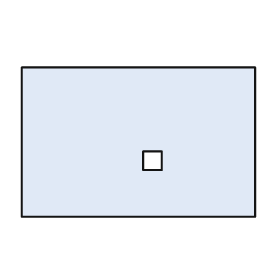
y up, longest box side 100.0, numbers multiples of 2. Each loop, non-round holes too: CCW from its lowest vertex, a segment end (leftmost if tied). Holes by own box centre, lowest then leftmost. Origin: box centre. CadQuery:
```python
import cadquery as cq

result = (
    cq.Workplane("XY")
    .moveTo(-50.0, -32.0)
    .lineTo(50.0, -32.0)
    .lineTo(50.0, 32.0)
    .lineTo(-50.0, 32.0)
    .close()
    .moveTo(2.0, -12.0)
    .lineTo(10.0, -12.0)
    .lineTo(10.0, -4.0)
    .lineTo(2.0, -4.0)
    .close()
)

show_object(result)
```